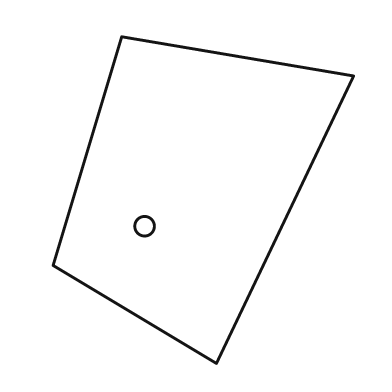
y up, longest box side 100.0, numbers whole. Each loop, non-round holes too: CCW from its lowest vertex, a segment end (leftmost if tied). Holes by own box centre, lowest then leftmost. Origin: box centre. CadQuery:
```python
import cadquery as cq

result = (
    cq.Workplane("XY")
    .moveTo(4.0, -50.0)
    .lineTo(46.0, 38.0)
    .lineTo(-25.0, 50.0)
    .lineTo(-46.0, -20.0)
    .close()
    .moveTo(-18.0, -8.0)
    .circle(3.0)
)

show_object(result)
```